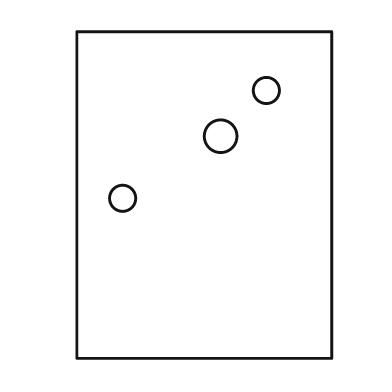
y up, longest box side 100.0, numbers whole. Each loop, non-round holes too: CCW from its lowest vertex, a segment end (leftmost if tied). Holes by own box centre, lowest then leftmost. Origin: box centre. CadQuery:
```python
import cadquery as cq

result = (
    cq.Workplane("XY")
    .moveTo(-39.0, -50.0)
    .lineTo(39.0, -50.0)
    .lineTo(39.0, 50.0)
    .lineTo(-39.0, 50.0)
    .close()
    .moveTo(-25.0, -1.0)
    .circle(4.0)
    .moveTo(5.0, 18.0)
    .circle(5.0)
    .moveTo(19.0, 32.0)
    .circle(4.0)
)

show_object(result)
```